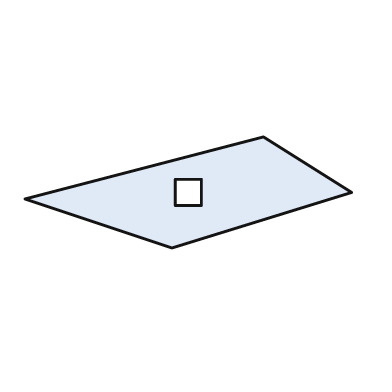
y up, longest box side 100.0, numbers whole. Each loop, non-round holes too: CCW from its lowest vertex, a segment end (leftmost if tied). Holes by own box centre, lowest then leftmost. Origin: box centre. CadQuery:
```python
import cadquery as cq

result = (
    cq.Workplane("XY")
    .moveTo(-5.0, -17.0)
    .lineTo(50.0, 0.0)
    .lineTo(23.0, 17.0)
    .lineTo(-50.0, -2.0)
    .close()
    .moveTo(-4.0, -4.0)
    .lineTo(4.0, -4.0)
    .lineTo(4.0, 4.0)
    .lineTo(-4.0, 4.0)
    .close()
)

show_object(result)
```